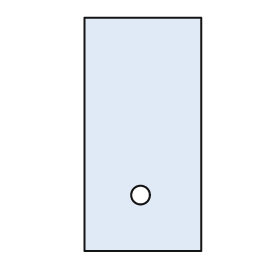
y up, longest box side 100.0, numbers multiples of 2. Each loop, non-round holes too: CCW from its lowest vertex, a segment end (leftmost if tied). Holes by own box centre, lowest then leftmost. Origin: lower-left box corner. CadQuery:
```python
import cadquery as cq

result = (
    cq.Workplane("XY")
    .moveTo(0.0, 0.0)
    .lineTo(50.0, 0.0)
    .lineTo(50.0, 100.0)
    .lineTo(0.0, 100.0)
    .close()
    .moveTo(24.0, 24.0)
    .circle(4.0)
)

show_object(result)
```